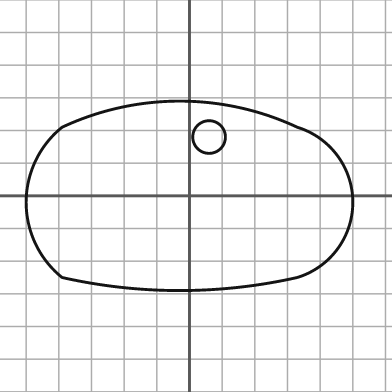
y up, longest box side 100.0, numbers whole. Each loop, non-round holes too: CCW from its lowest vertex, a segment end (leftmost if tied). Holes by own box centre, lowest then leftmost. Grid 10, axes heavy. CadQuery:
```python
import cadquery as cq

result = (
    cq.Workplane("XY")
    .moveTo(-39.0, -25.0)
    .threePointArc((-3.0, -29.0), (33.0, -25.0))
    .threePointArc((50.0, -2.0), (33.0, 21.0))
    .threePointArc((-3.0, 29.0), (-39.0, 21.0))
    .threePointArc((-50.0, -2.0), (-39.0, -25.0))
    .close()
    .moveTo(6.0, 18.0)
    .circle(5.0)
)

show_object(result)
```